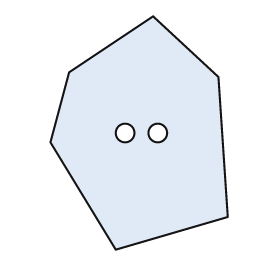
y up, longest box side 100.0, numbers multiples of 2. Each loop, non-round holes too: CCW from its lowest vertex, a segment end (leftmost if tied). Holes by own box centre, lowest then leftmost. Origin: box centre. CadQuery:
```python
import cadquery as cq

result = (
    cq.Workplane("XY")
    .moveTo(-10.0, -50.0)
    .lineTo(38.0, -36.0)
    .lineTo(34.0, 24.0)
    .lineTo(6.0, 50.0)
    .lineTo(-30.0, 26.0)
    .lineTo(-38.0, -4.0)
    .close()
    .moveTo(-6.0, 0.0)
    .circle(4.0)
    .moveTo(8.0, 0.0)
    .circle(4.0)
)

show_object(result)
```